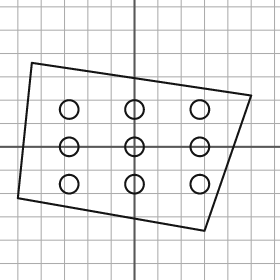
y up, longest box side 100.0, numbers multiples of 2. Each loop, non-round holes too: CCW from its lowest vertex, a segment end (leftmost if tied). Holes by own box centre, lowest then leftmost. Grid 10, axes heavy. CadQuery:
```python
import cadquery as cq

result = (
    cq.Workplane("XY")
    .moveTo(30.0, -36.0)
    .lineTo(50.0, 22.0)
    .lineTo(-44.0, 36.0)
    .lineTo(-50.0, -22.0)
    .close()
    .moveTo(-28.0, -16.0)
    .circle(4.0)
    .moveTo(0.0, -16.0)
    .circle(4.0)
    .moveTo(28.0, -16.0)
    .circle(4.0)
    .moveTo(-28.0, 0.0)
    .circle(4.0)
    .moveTo(0.0, 0.0)
    .circle(4.0)
    .moveTo(28.0, 0.0)
    .circle(4.0)
    .moveTo(-28.0, 16.0)
    .circle(4.0)
    .moveTo(0.0, 16.0)
    .circle(4.0)
    .moveTo(28.0, 16.0)
    .circle(4.0)
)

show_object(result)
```